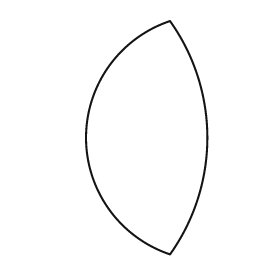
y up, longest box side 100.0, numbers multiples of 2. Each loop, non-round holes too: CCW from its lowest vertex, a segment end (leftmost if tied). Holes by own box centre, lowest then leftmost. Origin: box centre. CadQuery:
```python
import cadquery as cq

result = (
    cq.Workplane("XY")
    .moveTo(10.0, -50.0)
    .threePointArc((26.0, 0.0), (10.0, 50.0))
    .threePointArc((-26.0, 0.0), (10.0, -50.0))
    .close()
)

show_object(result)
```